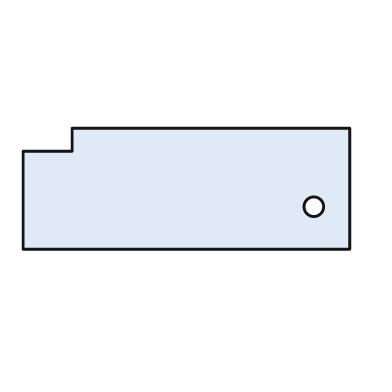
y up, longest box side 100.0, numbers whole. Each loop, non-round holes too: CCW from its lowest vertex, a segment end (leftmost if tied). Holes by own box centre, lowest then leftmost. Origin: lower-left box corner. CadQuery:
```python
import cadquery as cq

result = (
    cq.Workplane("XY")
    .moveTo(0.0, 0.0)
    .lineTo(100.0, 0.0)
    .lineTo(100.0, 37.0)
    .lineTo(15.0, 37.0)
    .lineTo(15.0, 30.0)
    .lineTo(0.0, 30.0)
    .close()
    .moveTo(89.0, 13.0)
    .circle(3.0)
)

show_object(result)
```